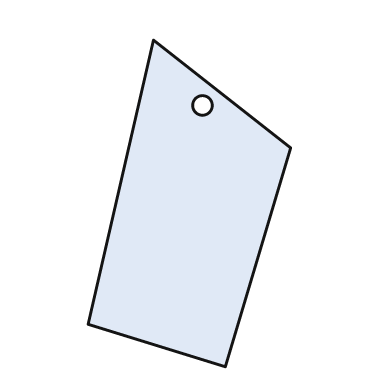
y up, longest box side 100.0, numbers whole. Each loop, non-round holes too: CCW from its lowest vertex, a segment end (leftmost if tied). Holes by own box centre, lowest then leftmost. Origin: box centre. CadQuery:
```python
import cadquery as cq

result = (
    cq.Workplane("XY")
    .moveTo(11.0, -50.0)
    .lineTo(31.0, 17.0)
    .lineTo(-11.0, 50.0)
    .lineTo(-31.0, -37.0)
    .close()
    .moveTo(4.0, 30.0)
    .circle(3.0)
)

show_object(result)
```